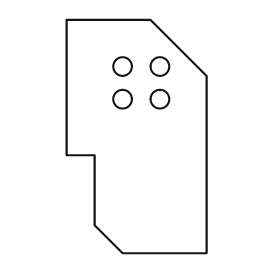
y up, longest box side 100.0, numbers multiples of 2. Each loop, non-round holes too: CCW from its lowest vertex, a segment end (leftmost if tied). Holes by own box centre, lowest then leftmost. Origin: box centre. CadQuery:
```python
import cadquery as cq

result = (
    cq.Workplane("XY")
    .moveTo(-6.0, -50.0)
    .lineTo(30.0, -50.0)
    .lineTo(30.0, 26.0)
    .lineTo(6.0, 50.0)
    .lineTo(-30.0, 50.0)
    .lineTo(-30.0, -8.0)
    .lineTo(-18.0, -8.0)
    .lineTo(-18.0, -38.0)
    .close()
    .moveTo(-6.0, 16.0)
    .circle(4.0)
    .moveTo(10.0, 16.0)
    .circle(4.0)
    .moveTo(-6.0, 30.0)
    .circle(4.0)
    .moveTo(10.0, 30.0)
    .circle(4.0)
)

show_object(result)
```